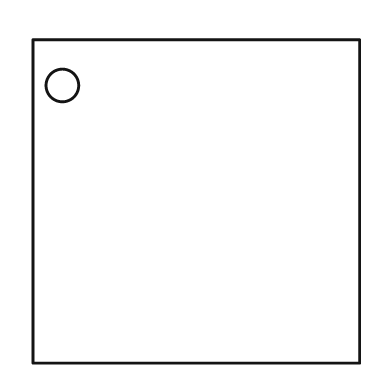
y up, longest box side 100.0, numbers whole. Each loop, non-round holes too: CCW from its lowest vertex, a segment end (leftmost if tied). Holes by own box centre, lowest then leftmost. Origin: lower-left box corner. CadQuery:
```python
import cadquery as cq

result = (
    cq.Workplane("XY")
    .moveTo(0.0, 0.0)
    .lineTo(100.0, 0.0)
    .lineTo(100.0, 99.0)
    .lineTo(0.0, 99.0)
    .close()
    .moveTo(9.0, 85.0)
    .circle(5.0)
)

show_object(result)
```